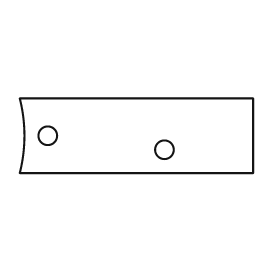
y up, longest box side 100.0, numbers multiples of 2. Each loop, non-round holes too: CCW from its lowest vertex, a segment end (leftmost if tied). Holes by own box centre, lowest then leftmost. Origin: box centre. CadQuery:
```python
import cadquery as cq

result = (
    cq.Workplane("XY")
    .moveTo(-50.0, -16.0)
    .lineTo(50.0, -16.0)
    .lineTo(50.0, 16.0)
    .lineTo(-50.0, 16.0)
    .threePointArc((-48.0, 0.0), (-50.0, -16.0))
    .close()
    .moveTo(12.0, -6.0)
    .circle(4.0)
    .moveTo(-38.0, 0.0)
    .circle(4.0)
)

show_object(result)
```